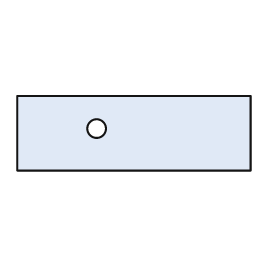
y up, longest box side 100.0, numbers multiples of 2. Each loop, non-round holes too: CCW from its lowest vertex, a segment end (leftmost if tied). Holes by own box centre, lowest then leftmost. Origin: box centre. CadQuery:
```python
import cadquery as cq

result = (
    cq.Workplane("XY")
    .moveTo(-50.0, -16.0)
    .lineTo(50.0, -16.0)
    .lineTo(50.0, 16.0)
    .lineTo(-50.0, 16.0)
    .close()
    .moveTo(-16.0, 2.0)
    .circle(4.0)
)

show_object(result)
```